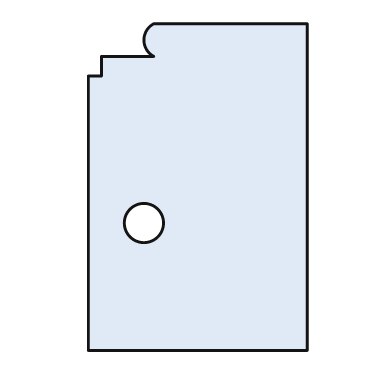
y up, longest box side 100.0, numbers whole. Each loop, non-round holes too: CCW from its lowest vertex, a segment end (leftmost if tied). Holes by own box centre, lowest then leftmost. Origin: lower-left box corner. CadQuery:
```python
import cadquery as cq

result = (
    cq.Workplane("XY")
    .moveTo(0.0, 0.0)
    .lineTo(67.0, 0.0)
    .lineTo(67.0, 100.0)
    .lineTo(20.0, 100.0)
    .threePointArc((17.0, 95.0), (20.0, 90.0))
    .lineTo(4.0, 90.0)
    .lineTo(4.0, 84.0)
    .lineTo(0.0, 84.0)
    .close()
    .moveTo(17.0, 39.0)
    .circle(6.0)
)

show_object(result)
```